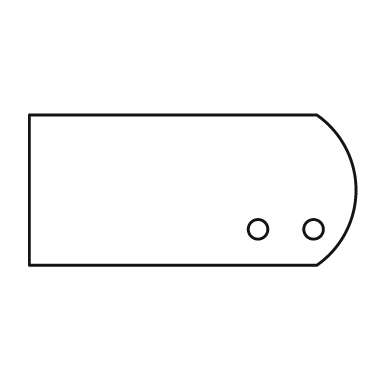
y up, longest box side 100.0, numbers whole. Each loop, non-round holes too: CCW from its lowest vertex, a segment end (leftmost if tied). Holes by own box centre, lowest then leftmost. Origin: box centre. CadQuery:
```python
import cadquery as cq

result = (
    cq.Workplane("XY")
    .moveTo(-50.0, -23.0)
    .lineTo(38.0, -23.0)
    .threePointArc((50.0, 0.0), (38.0, 23.0))
    .lineTo(-50.0, 23.0)
    .close()
    .moveTo(20.0, -12.0)
    .circle(3.0)
    .moveTo(37.0, -12.0)
    .circle(3.0)
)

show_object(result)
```